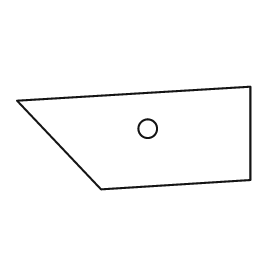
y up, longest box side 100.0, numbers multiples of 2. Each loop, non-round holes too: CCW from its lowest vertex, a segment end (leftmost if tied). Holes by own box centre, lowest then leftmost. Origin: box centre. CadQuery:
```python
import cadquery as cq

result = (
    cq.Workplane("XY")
    .moveTo(-14.0, -22.0)
    .lineTo(50.0, -18.0)
    .lineTo(50.0, 22.0)
    .lineTo(-50.0, 16.0)
    .close()
    .moveTo(6.0, 4.0)
    .circle(4.0)
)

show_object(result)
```